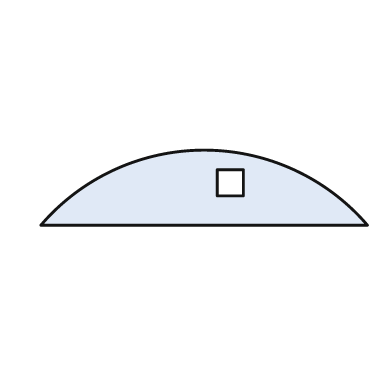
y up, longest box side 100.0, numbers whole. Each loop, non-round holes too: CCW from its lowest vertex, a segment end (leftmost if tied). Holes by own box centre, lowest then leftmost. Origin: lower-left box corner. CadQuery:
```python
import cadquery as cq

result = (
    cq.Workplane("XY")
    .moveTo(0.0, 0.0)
    .lineTo(100.0, 0.0)
    .threePointArc((50.0, 23.0), (0.0, 0.0))
    .close()
    .moveTo(54.0, 9.0)
    .lineTo(62.0, 9.0)
    .lineTo(62.0, 17.0)
    .lineTo(54.0, 17.0)
    .close()
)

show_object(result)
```